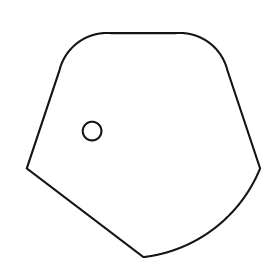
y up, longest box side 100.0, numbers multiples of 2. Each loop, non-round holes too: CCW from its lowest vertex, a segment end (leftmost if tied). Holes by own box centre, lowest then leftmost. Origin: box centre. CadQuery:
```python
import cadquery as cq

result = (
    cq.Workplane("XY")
    .moveTo(0.0, -48.0)
    .threePointArc((30.0, -36.0), (50.0, -10.0))
    .lineTo(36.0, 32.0)
    .threePointArc((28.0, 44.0), (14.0, 48.0))
    .lineTo(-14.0, 48.0)
    .threePointArc((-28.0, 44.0), (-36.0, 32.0))
    .lineTo(-50.0, -10.0)
    .close()
    .moveTo(-22.0, 6.0)
    .circle(4.0)
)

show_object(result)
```